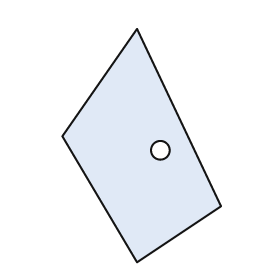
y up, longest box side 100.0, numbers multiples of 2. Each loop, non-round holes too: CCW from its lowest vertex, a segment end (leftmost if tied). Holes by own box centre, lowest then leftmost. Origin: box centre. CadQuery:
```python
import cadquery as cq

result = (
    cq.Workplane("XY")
    .moveTo(-2.0, -50.0)
    .lineTo(34.0, -26.0)
    .lineTo(-2.0, 50.0)
    .lineTo(-34.0, 4.0)
    .close()
    .moveTo(8.0, -2.0)
    .circle(4.0)
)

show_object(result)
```